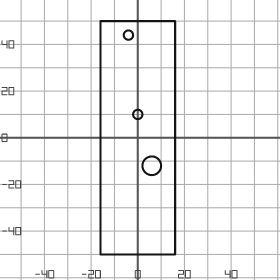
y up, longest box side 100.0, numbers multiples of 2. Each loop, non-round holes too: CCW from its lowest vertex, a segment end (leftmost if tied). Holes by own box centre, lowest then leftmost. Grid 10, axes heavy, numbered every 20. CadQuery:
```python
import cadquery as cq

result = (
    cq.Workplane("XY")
    .moveTo(-16.0, -50.0)
    .lineTo(16.0, -50.0)
    .lineTo(16.0, 50.0)
    .lineTo(-16.0, 50.0)
    .close()
    .moveTo(6.0, -12.0)
    .circle(4.0)
    .moveTo(0.0, 10.0)
    .circle(2.0)
    .moveTo(-4.0, 44.0)
    .circle(2.0)
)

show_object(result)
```